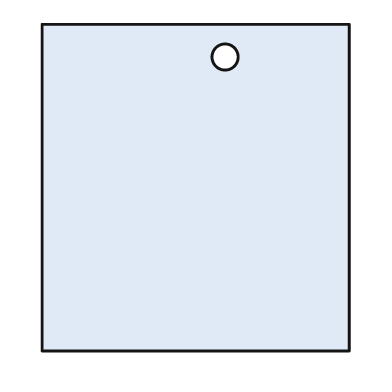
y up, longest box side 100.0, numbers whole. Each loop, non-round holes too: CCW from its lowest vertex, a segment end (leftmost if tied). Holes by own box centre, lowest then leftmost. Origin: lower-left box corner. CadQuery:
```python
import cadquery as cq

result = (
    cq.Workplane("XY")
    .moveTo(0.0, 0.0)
    .lineTo(94.0, 0.0)
    .lineTo(94.0, 100.0)
    .lineTo(0.0, 100.0)
    .close()
    .moveTo(56.0, 90.0)
    .circle(4.0)
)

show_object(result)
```